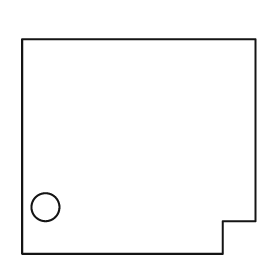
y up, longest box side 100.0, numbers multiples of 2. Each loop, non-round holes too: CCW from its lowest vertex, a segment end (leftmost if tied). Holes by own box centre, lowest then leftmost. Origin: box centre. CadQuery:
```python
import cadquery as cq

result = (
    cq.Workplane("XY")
    .moveTo(-50.0, -46.0)
    .lineTo(36.0, -46.0)
    .lineTo(36.0, -32.0)
    .lineTo(50.0, -32.0)
    .lineTo(50.0, 46.0)
    .lineTo(-50.0, 46.0)
    .close()
    .moveTo(-40.0, -26.0)
    .circle(6.0)
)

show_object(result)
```